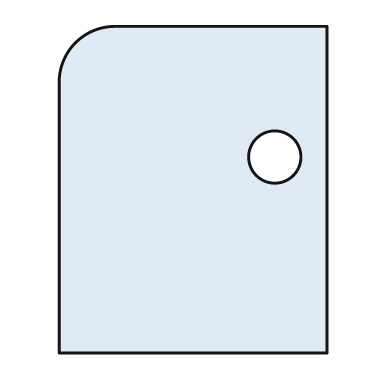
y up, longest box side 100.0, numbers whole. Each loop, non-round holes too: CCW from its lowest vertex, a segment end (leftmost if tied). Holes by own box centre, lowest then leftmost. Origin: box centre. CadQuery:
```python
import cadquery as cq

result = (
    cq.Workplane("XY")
    .moveTo(-41.0, -50.0)
    .lineTo(41.0, -50.0)
    .lineTo(41.0, 50.0)
    .lineTo(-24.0, 50.0)
    .threePointArc((-36.0, 45.0), (-41.0, 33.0))
    .close()
    .moveTo(25.0, 10.0)
    .circle(8.0)
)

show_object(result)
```